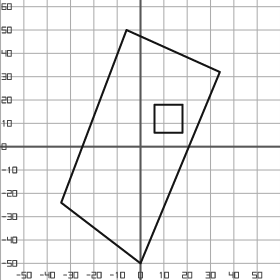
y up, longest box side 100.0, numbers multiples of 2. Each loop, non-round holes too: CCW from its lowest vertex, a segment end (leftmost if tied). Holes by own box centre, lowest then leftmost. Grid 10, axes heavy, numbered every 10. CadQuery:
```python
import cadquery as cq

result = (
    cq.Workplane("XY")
    .moveTo(0.0, -50.0)
    .lineTo(34.0, 32.0)
    .lineTo(-6.0, 50.0)
    .lineTo(-34.0, -24.0)
    .close()
    .moveTo(6.0, 6.0)
    .lineTo(18.0, 6.0)
    .lineTo(18.0, 18.0)
    .lineTo(6.0, 18.0)
    .close()
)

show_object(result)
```